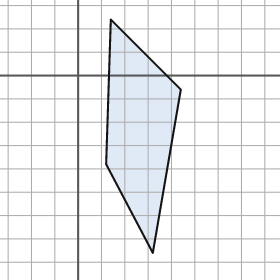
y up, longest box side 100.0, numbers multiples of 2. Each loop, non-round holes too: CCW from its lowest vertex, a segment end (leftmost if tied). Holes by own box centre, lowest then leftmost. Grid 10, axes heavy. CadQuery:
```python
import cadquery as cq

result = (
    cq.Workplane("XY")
    .moveTo(32.0, -76.0)
    .lineTo(44.0, -6.0)
    .lineTo(14.0, 24.0)
    .lineTo(12.0, -38.0)
    .close()
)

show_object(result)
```